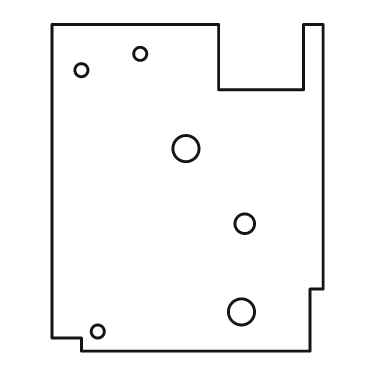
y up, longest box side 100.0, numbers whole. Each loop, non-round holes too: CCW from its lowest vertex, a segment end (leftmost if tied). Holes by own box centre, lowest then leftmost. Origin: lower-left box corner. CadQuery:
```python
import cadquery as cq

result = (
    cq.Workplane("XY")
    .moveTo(9.0, 0.0)
    .lineTo(79.0, 0.0)
    .lineTo(79.0, 19.0)
    .lineTo(83.0, 19.0)
    .lineTo(83.0, 100.0)
    .lineTo(77.0, 100.0)
    .lineTo(77.0, 80.0)
    .lineTo(51.0, 80.0)
    .lineTo(51.0, 100.0)
    .lineTo(0.0, 100.0)
    .lineTo(0.0, 4.0)
    .lineTo(9.0, 4.0)
    .close()
    .moveTo(14.0, 6.0)
    .circle(2.0)
    .moveTo(58.0, 12.0)
    .circle(4.0)
    .moveTo(59.0, 39.0)
    .circle(3.0)
    .moveTo(41.0, 62.0)
    .circle(4.0)
    .moveTo(9.0, 86.0)
    .circle(2.0)
    .moveTo(27.0, 91.0)
    .circle(2.0)
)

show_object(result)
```